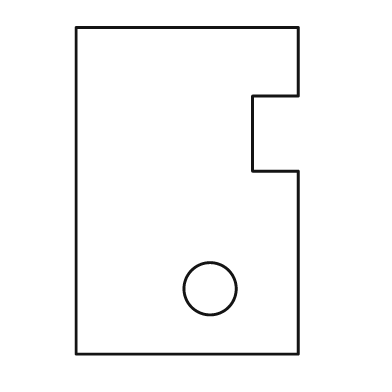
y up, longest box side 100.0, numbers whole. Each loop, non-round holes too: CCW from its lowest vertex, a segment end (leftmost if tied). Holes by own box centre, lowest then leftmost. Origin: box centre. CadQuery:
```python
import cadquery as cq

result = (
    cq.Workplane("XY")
    .moveTo(-34.0, -50.0)
    .lineTo(34.0, -50.0)
    .lineTo(34.0, 6.0)
    .lineTo(20.0, 6.0)
    .lineTo(20.0, 29.0)
    .lineTo(34.0, 29.0)
    .lineTo(34.0, 50.0)
    .lineTo(-34.0, 50.0)
    .close()
    .moveTo(7.0, -30.0)
    .circle(8.0)
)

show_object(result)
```